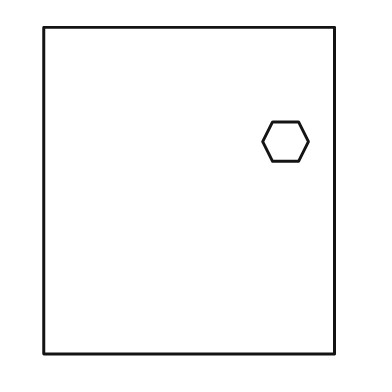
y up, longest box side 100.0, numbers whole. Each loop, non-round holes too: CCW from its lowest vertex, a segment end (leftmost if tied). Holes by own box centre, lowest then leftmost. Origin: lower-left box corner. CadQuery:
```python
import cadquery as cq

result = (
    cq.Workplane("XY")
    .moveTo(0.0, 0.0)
    .lineTo(89.0, 0.0)
    .lineTo(89.0, 100.0)
    .lineTo(0.0, 100.0)
    .close()
    .moveTo(70.0, 59.0)
    .lineTo(78.0, 59.0)
    .lineTo(81.0, 65.0)
    .lineTo(78.0, 71.0)
    .lineTo(70.0, 71.0)
    .lineTo(67.0, 65.0)
    .close()
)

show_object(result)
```